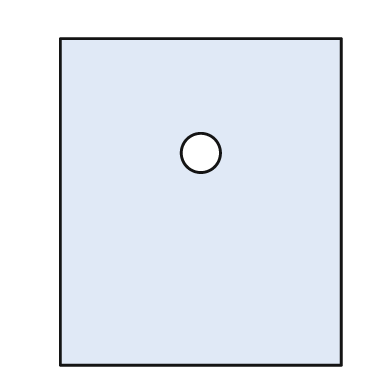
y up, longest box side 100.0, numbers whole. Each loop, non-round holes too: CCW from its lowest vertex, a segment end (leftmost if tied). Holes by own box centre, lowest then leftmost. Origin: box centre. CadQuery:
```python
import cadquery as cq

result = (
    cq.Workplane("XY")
    .moveTo(-43.0, -50.0)
    .lineTo(43.0, -50.0)
    .lineTo(43.0, 50.0)
    .lineTo(-43.0, 50.0)
    .close()
    .moveTo(0.0, 15.0)
    .circle(6.0)
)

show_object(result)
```